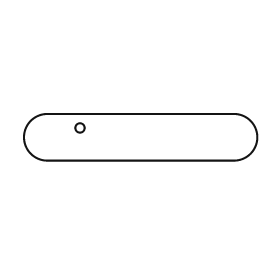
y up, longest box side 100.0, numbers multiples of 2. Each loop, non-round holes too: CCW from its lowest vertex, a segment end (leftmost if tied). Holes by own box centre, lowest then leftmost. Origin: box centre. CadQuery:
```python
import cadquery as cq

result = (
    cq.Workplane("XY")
    .moveTo(-40.0, -10.0)
    .lineTo(40.0, -10.0)
    .threePointArc((50.0, 0.0), (40.0, 10.0))
    .lineTo(-40.0, 10.0)
    .threePointArc((-50.0, 0.0), (-40.0, -10.0))
    .close()
    .moveTo(-26.0, 4.0)
    .circle(2.0)
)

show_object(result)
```